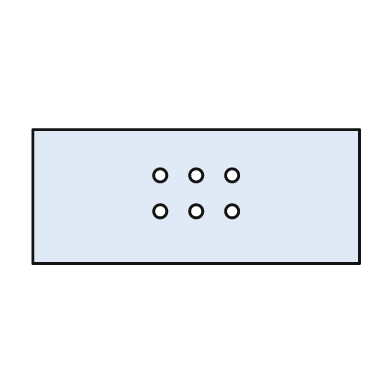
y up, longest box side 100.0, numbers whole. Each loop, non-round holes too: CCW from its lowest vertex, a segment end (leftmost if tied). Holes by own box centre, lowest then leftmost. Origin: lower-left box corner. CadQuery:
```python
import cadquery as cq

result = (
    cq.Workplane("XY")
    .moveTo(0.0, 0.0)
    .lineTo(100.0, 0.0)
    .lineTo(100.0, 41.0)
    .lineTo(0.0, 41.0)
    .close()
    .moveTo(39.0, 16.0)
    .circle(2.0)
    .moveTo(50.0, 16.0)
    .circle(2.0)
    .moveTo(61.0, 16.0)
    .circle(2.0)
    .moveTo(39.0, 27.0)
    .circle(2.0)
    .moveTo(50.0, 27.0)
    .circle(2.0)
    .moveTo(61.0, 27.0)
    .circle(2.0)
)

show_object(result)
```